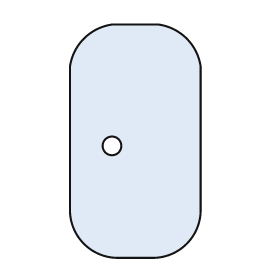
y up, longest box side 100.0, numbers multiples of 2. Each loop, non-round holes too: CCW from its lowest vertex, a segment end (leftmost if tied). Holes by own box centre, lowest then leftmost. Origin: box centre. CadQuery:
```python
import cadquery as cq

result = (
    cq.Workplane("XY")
    .moveTo(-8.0, -50.0)
    .lineTo(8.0, -50.0)
    .threePointArc((22.0, -44.0), (28.0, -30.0))
    .lineTo(28.0, 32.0)
    .threePointArc((22.0, 44.0), (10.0, 50.0))
    .lineTo(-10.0, 50.0)
    .threePointArc((-22.0, 44.0), (-28.0, 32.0))
    .lineTo(-28.0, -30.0)
    .threePointArc((-22.0, -44.0), (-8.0, -50.0))
    .close()
    .moveTo(-10.0, -2.0)
    .circle(4.0)
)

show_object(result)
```